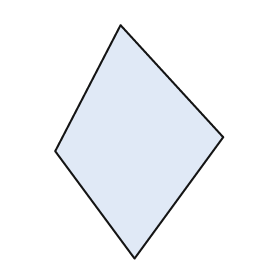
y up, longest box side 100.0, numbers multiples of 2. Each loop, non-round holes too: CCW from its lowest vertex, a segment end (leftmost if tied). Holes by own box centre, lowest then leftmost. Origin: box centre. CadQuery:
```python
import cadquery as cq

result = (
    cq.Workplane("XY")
    .moveTo(-2.0, -50.0)
    .lineTo(36.0, 2.0)
    .lineTo(-8.0, 50.0)
    .lineTo(-36.0, -4.0)
    .close()
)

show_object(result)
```